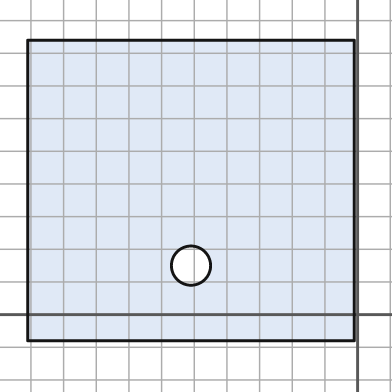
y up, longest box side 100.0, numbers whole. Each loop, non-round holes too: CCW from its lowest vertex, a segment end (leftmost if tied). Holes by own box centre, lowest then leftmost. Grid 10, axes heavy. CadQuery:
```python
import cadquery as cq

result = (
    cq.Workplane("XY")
    .moveTo(-101.0, -8.0)
    .lineTo(-1.0, -8.0)
    .lineTo(-1.0, 84.0)
    .lineTo(-101.0, 84.0)
    .close()
    .moveTo(-51.0, 15.0)
    .circle(6.0)
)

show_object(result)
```